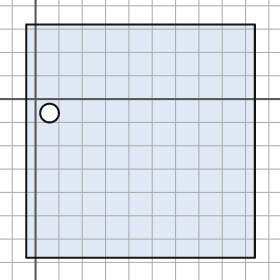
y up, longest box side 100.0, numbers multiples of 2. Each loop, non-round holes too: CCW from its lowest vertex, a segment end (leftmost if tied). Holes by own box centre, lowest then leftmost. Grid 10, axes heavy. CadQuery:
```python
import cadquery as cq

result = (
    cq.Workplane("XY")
    .moveTo(-4.0, -68.0)
    .lineTo(94.0, -68.0)
    .lineTo(94.0, 32.0)
    .lineTo(-4.0, 32.0)
    .close()
    .moveTo(6.0, -6.0)
    .circle(4.0)
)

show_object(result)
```